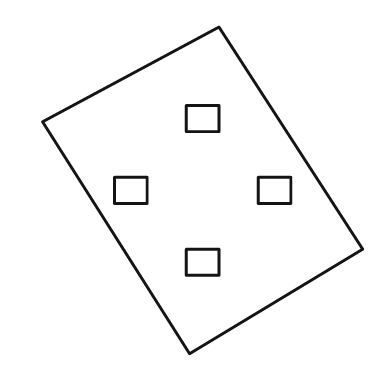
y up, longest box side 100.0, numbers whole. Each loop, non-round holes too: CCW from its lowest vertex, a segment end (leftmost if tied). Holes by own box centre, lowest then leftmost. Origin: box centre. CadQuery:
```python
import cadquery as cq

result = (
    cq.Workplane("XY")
    .moveTo(-4.0, -50.0)
    .lineTo(49.0, -18.0)
    .lineTo(5.0, 50.0)
    .lineTo(-49.0, 21.0)
    .close()
    .moveTo(-5.0, -26.0)
    .lineTo(5.0, -26.0)
    .lineTo(5.0, -18.0)
    .lineTo(-5.0, -18.0)
    .close()
    .moveTo(-27.0, -4.0)
    .lineTo(-17.0, -4.0)
    .lineTo(-17.0, 4.0)
    .lineTo(-27.0, 4.0)
    .close()
    .moveTo(17.0, -4.0)
    .lineTo(27.0, -4.0)
    .lineTo(27.0, 4.0)
    .lineTo(17.0, 4.0)
    .close()
    .moveTo(-5.0, 18.0)
    .lineTo(5.0, 18.0)
    .lineTo(5.0, 26.0)
    .lineTo(-5.0, 26.0)
    .close()
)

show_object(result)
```